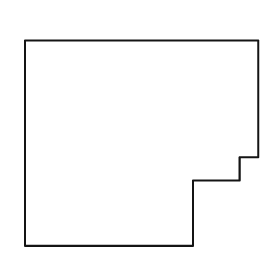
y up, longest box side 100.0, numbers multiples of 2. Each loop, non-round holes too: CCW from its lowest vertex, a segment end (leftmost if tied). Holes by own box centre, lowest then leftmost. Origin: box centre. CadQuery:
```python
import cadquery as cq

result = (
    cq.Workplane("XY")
    .moveTo(-50.0, -44.0)
    .lineTo(22.0, -44.0)
    .lineTo(22.0, -16.0)
    .lineTo(42.0, -16.0)
    .lineTo(42.0, -6.0)
    .lineTo(50.0, -6.0)
    .lineTo(50.0, 44.0)
    .lineTo(-50.0, 44.0)
    .close()
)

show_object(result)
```